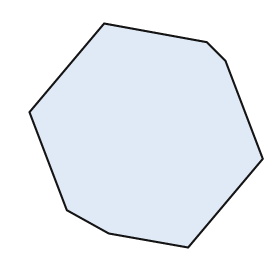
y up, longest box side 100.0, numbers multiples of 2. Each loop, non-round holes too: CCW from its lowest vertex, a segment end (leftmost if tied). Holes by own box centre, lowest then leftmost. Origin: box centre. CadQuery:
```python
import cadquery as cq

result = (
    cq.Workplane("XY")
    .moveTo(18.0, -48.0)
    .lineTo(50.0, -10.0)
    .lineTo(34.0, 32.0)
    .lineTo(26.0, 40.0)
    .lineTo(-18.0, 48.0)
    .lineTo(-50.0, 10.0)
    .lineTo(-34.0, -32.0)
    .lineTo(-16.0, -42.0)
    .close()
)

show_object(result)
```